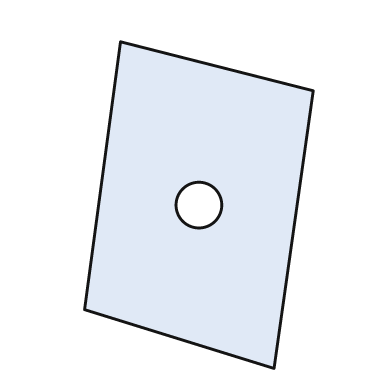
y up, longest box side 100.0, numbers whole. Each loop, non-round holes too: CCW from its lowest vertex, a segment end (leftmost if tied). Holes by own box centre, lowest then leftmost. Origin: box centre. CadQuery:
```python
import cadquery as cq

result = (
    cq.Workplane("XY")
    .moveTo(23.0, -50.0)
    .lineTo(35.0, 35.0)
    .lineTo(-24.0, 50.0)
    .lineTo(-35.0, -32.0)
    .close()
    .moveTo(0.0, 0.0)
    .circle(7.0)
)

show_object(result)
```